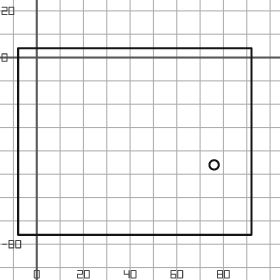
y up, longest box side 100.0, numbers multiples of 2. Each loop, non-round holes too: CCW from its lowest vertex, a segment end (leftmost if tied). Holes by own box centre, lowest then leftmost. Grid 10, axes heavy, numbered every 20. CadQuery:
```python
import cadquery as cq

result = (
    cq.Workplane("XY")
    .moveTo(-8.0, -76.0)
    .lineTo(92.0, -76.0)
    .lineTo(92.0, 4.0)
    .lineTo(-8.0, 4.0)
    .close()
    .moveTo(76.0, -46.0)
    .circle(2.0)
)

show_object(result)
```